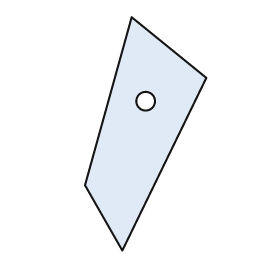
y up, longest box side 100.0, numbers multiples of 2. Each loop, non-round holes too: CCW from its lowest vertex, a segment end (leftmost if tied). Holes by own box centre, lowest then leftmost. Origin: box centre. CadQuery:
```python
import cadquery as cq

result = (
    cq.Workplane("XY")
    .moveTo(-10.0, -50.0)
    .lineTo(26.0, 24.0)
    .lineTo(-6.0, 50.0)
    .lineTo(-26.0, -22.0)
    .close()
    .moveTo(0.0, 14.0)
    .circle(4.0)
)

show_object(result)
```